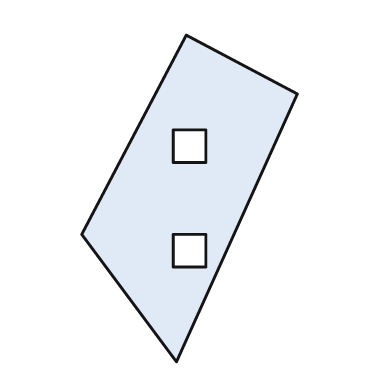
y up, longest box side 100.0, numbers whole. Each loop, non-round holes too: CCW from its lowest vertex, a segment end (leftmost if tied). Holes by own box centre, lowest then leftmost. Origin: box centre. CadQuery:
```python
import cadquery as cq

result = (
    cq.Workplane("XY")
    .moveTo(-4.0, -50.0)
    .lineTo(33.0, 32.0)
    .lineTo(-1.0, 50.0)
    .lineTo(-33.0, -11.0)
    .close()
    .moveTo(-5.0, -21.0)
    .lineTo(5.0, -21.0)
    .lineTo(5.0, -11.0)
    .lineTo(-5.0, -11.0)
    .close()
    .moveTo(-5.0, 11.0)
    .lineTo(5.0, 11.0)
    .lineTo(5.0, 21.0)
    .lineTo(-5.0, 21.0)
    .close()
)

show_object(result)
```